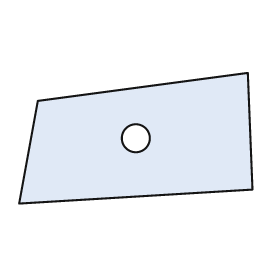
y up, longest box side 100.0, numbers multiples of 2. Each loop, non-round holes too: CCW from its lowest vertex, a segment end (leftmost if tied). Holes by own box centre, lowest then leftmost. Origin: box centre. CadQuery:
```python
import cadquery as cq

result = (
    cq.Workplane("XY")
    .moveTo(-50.0, -28.0)
    .lineTo(50.0, -22.0)
    .lineTo(48.0, 28.0)
    .lineTo(-42.0, 16.0)
    .close()
    .moveTo(0.0, 0.0)
    .circle(6.0)
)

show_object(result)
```